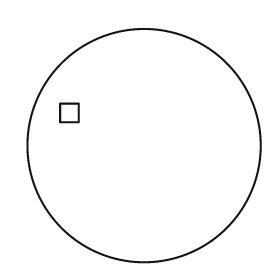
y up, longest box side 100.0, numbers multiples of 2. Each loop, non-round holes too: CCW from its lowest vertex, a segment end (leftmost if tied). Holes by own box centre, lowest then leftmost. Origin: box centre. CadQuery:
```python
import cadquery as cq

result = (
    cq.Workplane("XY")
    .moveTo(0.0, 0.0)
    .circle(50.0)
    .moveTo(-36.0, 10.0)
    .lineTo(-28.0, 10.0)
    .lineTo(-28.0, 18.0)
    .lineTo(-36.0, 18.0)
    .close()
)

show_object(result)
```